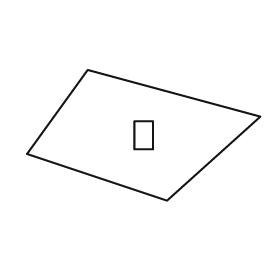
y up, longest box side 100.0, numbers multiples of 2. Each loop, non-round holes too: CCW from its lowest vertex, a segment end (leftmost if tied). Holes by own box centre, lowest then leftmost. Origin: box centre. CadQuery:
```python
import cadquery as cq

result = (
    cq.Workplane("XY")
    .moveTo(10.0, -28.0)
    .lineTo(50.0, 8.0)
    .lineTo(-24.0, 28.0)
    .lineTo(-50.0, -8.0)
    .close()
    .moveTo(-4.0, -6.0)
    .lineTo(4.0, -6.0)
    .lineTo(4.0, 6.0)
    .lineTo(-4.0, 6.0)
    .close()
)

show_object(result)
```